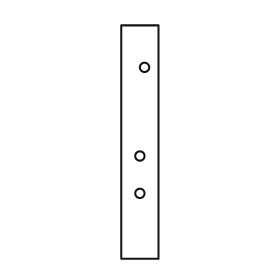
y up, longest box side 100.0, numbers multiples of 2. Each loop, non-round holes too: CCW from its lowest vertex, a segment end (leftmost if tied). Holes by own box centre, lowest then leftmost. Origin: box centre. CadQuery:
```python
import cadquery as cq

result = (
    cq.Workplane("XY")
    .moveTo(-8.0, -50.0)
    .lineTo(8.0, -50.0)
    .lineTo(8.0, 50.0)
    .lineTo(-8.0, 50.0)
    .close()
    .moveTo(0.0, -22.0)
    .circle(2.0)
    .moveTo(0.0, -6.0)
    .circle(2.0)
    .moveTo(2.0, 32.0)
    .circle(2.0)
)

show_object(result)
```